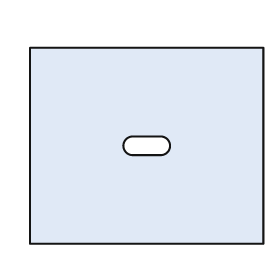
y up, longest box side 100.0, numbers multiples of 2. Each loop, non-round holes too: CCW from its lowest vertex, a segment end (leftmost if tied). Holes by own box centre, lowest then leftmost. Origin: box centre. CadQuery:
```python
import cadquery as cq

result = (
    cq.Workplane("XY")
    .moveTo(-50.0, -42.0)
    .lineTo(50.0, -42.0)
    .lineTo(50.0, 42.0)
    .lineTo(-50.0, 42.0)
    .close()
    .moveTo(-6.0, -4.0)
    .lineTo(6.0, -4.0)
    .threePointArc((10.0, 0.0), (6.0, 4.0))
    .lineTo(-6.0, 4.0)
    .threePointArc((-10.0, 0.0), (-6.0, -4.0))
    .close()
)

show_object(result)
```